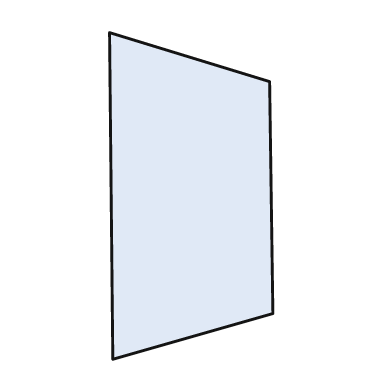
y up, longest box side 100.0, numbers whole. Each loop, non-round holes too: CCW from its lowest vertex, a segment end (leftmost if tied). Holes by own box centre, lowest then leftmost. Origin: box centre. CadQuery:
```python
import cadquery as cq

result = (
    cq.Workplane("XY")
    .moveTo(-24.0, -50.0)
    .lineTo(25.0, -36.0)
    .lineTo(24.0, 35.0)
    .lineTo(-25.0, 50.0)
    .close()
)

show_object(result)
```